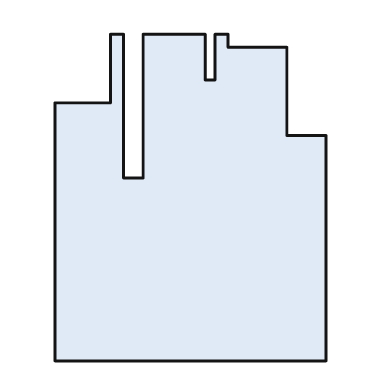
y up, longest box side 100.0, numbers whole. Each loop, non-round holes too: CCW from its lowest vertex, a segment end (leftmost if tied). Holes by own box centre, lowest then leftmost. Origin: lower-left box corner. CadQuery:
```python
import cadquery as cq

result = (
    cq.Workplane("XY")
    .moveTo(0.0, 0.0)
    .lineTo(83.0, 0.0)
    .lineTo(83.0, 69.0)
    .lineTo(71.0, 69.0)
    .lineTo(71.0, 96.0)
    .lineTo(53.0, 96.0)
    .lineTo(53.0, 100.0)
    .lineTo(49.0, 100.0)
    .lineTo(49.0, 86.0)
    .lineTo(46.0, 86.0)
    .lineTo(46.0, 100.0)
    .lineTo(27.0, 100.0)
    .lineTo(27.0, 56.0)
    .lineTo(21.0, 56.0)
    .lineTo(21.0, 100.0)
    .lineTo(17.0, 100.0)
    .lineTo(17.0, 79.0)
    .lineTo(0.0, 79.0)
    .close()
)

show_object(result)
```